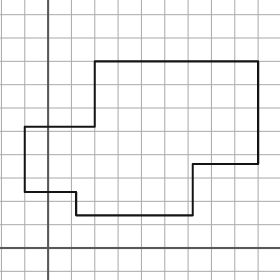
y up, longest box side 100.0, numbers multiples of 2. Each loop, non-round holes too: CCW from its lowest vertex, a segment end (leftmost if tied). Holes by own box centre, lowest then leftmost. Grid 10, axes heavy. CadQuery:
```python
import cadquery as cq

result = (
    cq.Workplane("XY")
    .moveTo(12.0, 14.0)
    .lineTo(62.0, 14.0)
    .lineTo(62.0, 36.0)
    .lineTo(90.0, 36.0)
    .lineTo(90.0, 80.0)
    .lineTo(20.0, 80.0)
    .lineTo(20.0, 52.0)
    .lineTo(-10.0, 52.0)
    .lineTo(-10.0, 24.0)
    .lineTo(12.0, 24.0)
    .close()
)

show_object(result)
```